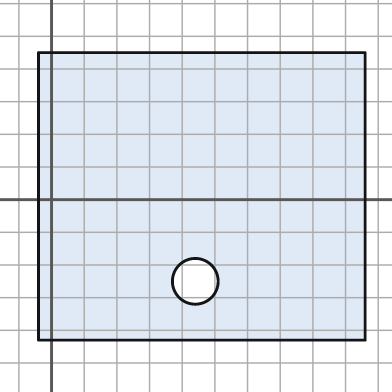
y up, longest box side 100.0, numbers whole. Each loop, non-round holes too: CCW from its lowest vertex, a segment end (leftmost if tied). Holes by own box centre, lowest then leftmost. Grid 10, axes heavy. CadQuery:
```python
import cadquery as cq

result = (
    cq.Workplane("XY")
    .moveTo(-4.0, -43.0)
    .lineTo(96.0, -43.0)
    .lineTo(96.0, 45.0)
    .lineTo(-4.0, 45.0)
    .close()
    .moveTo(44.0, -25.0)
    .circle(7.0)
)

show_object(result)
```